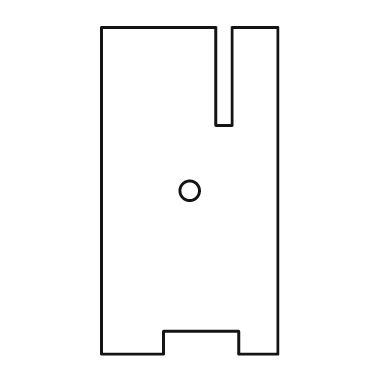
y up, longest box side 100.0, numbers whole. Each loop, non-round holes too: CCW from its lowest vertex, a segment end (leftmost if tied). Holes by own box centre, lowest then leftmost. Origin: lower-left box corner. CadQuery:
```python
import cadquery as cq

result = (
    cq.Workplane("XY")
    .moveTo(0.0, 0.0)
    .lineTo(19.0, 0.0)
    .lineTo(19.0, 7.0)
    .lineTo(42.0, 7.0)
    .lineTo(42.0, 0.0)
    .lineTo(54.0, 0.0)
    .lineTo(54.0, 100.0)
    .lineTo(40.0, 100.0)
    .lineTo(40.0, 70.0)
    .lineTo(35.0, 70.0)
    .lineTo(35.0, 100.0)
    .lineTo(0.0, 100.0)
    .close()
    .moveTo(27.0, 50.0)
    .circle(3.0)
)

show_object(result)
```